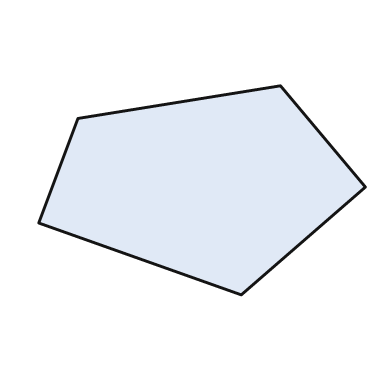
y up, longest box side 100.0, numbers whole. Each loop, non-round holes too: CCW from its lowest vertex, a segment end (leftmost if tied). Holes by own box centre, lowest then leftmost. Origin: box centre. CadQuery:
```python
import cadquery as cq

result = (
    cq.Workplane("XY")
    .moveTo(12.0, -32.0)
    .lineTo(50.0, 1.0)
    .lineTo(24.0, 32.0)
    .lineTo(-38.0, 22.0)
    .lineTo(-50.0, -10.0)
    .close()
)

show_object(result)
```